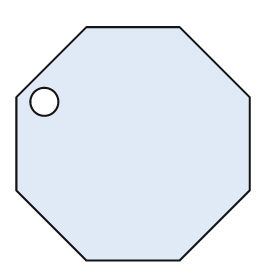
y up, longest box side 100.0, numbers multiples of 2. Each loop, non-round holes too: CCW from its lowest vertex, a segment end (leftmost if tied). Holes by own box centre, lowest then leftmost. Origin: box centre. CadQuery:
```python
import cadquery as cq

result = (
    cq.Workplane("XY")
    .moveTo(-20.0, -50.0)
    .lineTo(20.0, -50.0)
    .lineTo(50.0, -20.0)
    .lineTo(50.0, 20.0)
    .lineTo(20.0, 50.0)
    .lineTo(-20.0, 50.0)
    .lineTo(-50.0, 20.0)
    .lineTo(-50.0, -20.0)
    .close()
    .moveTo(-38.0, 18.0)
    .circle(6.0)
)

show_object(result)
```